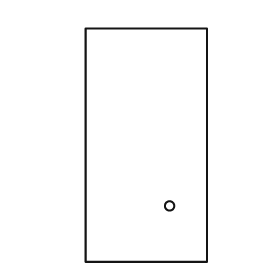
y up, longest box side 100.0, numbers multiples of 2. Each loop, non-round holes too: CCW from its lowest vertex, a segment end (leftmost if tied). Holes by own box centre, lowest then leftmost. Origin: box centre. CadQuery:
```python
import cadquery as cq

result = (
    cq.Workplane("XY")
    .moveTo(-26.0, -50.0)
    .lineTo(26.0, -50.0)
    .lineTo(26.0, 50.0)
    .lineTo(-26.0, 50.0)
    .close()
    .moveTo(10.0, -26.0)
    .circle(2.0)
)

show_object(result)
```